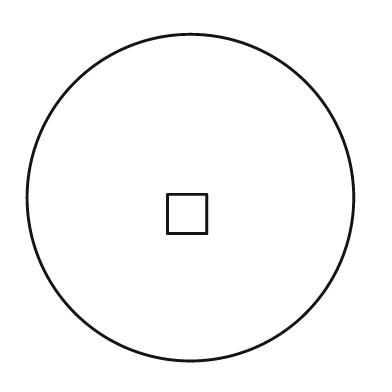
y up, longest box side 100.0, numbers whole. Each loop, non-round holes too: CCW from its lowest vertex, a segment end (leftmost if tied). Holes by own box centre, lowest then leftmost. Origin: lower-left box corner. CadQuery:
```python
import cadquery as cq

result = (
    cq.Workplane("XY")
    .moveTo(50.0, 50.0)
    .circle(50.0)
    .moveTo(43.0, 39.0)
    .lineTo(55.0, 39.0)
    .lineTo(55.0, 51.0)
    .lineTo(43.0, 51.0)
    .close()
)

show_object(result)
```